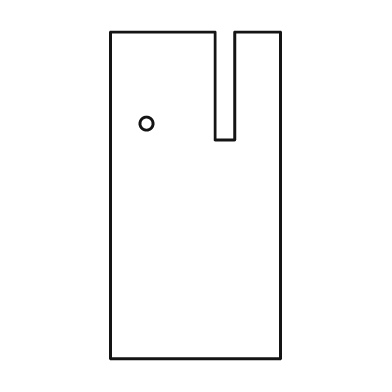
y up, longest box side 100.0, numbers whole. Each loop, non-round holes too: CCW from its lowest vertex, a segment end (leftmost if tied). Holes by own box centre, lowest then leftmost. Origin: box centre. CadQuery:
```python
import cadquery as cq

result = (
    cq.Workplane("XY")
    .moveTo(-26.0, -50.0)
    .lineTo(26.0, -50.0)
    .lineTo(26.0, 50.0)
    .lineTo(12.0, 50.0)
    .lineTo(12.0, 17.0)
    .lineTo(6.0, 17.0)
    .lineTo(6.0, 50.0)
    .lineTo(-26.0, 50.0)
    .close()
    .moveTo(-15.0, 22.0)
    .circle(2.0)
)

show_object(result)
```